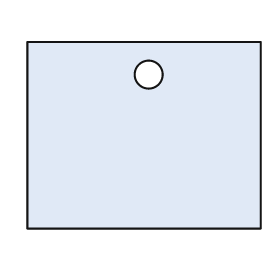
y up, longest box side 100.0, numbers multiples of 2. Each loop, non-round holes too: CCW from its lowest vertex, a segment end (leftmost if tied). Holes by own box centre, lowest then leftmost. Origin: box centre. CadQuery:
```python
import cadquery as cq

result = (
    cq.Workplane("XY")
    .moveTo(-50.0, -40.0)
    .lineTo(50.0, -40.0)
    .lineTo(50.0, 40.0)
    .lineTo(-50.0, 40.0)
    .close()
    .moveTo(2.0, 26.0)
    .circle(6.0)
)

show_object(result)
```